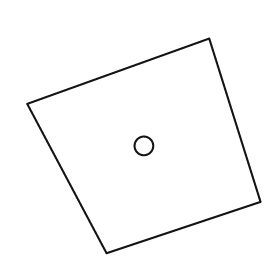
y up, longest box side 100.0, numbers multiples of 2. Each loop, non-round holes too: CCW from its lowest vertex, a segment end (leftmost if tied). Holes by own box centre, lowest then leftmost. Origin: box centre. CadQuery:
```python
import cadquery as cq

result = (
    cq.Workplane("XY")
    .moveTo(-16.0, -46.0)
    .lineTo(50.0, -24.0)
    .lineTo(28.0, 46.0)
    .lineTo(-50.0, 18.0)
    .close()
    .moveTo(0.0, 0.0)
    .circle(4.0)
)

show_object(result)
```